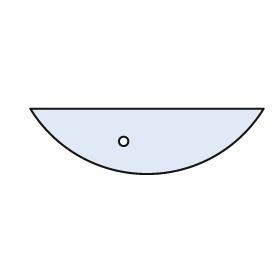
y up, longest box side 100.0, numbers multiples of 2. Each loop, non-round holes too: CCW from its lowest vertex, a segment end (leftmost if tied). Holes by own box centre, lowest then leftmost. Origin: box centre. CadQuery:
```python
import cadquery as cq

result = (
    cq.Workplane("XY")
    .moveTo(-50.0, 14.0)
    .threePointArc((0.0, -14.0), (50.0, 14.0))
    .close()
    .moveTo(-10.0, 0.0)
    .circle(2.0)
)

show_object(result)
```